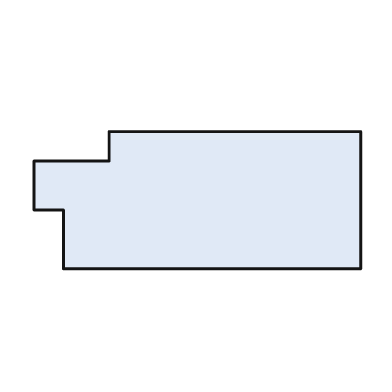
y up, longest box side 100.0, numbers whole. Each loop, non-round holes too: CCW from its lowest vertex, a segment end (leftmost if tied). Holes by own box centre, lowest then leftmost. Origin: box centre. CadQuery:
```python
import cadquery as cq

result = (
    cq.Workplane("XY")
    .moveTo(-41.0, -21.0)
    .lineTo(50.0, -21.0)
    .lineTo(50.0, 21.0)
    .lineTo(-27.0, 21.0)
    .lineTo(-27.0, 12.0)
    .lineTo(-50.0, 12.0)
    .lineTo(-50.0, -3.0)
    .lineTo(-41.0, -3.0)
    .close()
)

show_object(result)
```